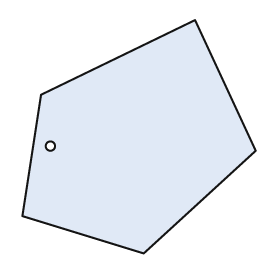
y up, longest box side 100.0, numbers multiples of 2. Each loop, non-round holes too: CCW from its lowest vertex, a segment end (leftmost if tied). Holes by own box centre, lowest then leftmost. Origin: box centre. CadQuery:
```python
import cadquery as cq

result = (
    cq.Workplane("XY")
    .moveTo(2.0, -50.0)
    .lineTo(50.0, -6.0)
    .lineTo(24.0, 50.0)
    .lineTo(-42.0, 18.0)
    .lineTo(-50.0, -34.0)
    .close()
    .moveTo(-38.0, -4.0)
    .circle(2.0)
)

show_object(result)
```